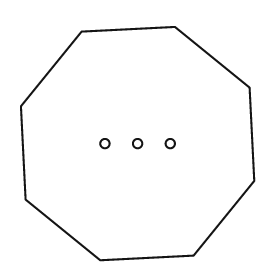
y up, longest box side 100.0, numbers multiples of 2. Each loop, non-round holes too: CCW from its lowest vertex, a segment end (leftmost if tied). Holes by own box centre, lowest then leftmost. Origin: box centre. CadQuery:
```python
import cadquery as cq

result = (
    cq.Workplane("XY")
    .moveTo(-16.0, -50.0)
    .lineTo(24.0, -48.0)
    .lineTo(50.0, -16.0)
    .lineTo(48.0, 24.0)
    .lineTo(16.0, 50.0)
    .lineTo(-24.0, 48.0)
    .lineTo(-50.0, 16.0)
    .lineTo(-48.0, -24.0)
    .close()
    .moveTo(-14.0, 0.0)
    .circle(2.0)
    .moveTo(0.0, 0.0)
    .circle(2.0)
    .moveTo(14.0, 0.0)
    .circle(2.0)
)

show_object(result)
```